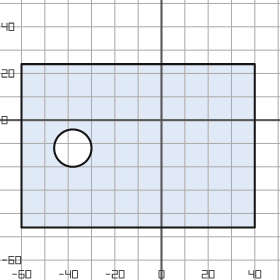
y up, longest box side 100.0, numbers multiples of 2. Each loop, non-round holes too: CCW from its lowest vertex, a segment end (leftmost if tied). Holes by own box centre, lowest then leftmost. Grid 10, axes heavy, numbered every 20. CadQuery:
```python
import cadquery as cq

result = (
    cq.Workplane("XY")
    .moveTo(-60.0, -46.0)
    .lineTo(40.0, -46.0)
    .lineTo(40.0, 24.0)
    .lineTo(-60.0, 24.0)
    .close()
    .moveTo(-38.0, -12.0)
    .circle(8.0)
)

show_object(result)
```